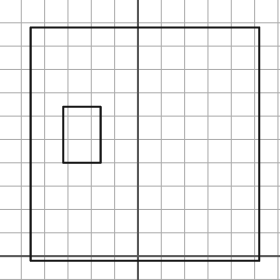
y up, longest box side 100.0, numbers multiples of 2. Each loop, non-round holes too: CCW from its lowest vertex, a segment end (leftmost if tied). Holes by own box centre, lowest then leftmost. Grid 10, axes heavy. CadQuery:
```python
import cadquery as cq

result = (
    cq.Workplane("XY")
    .moveTo(-46.0, -2.0)
    .lineTo(52.0, -2.0)
    .lineTo(52.0, 98.0)
    .lineTo(-46.0, 98.0)
    .close()
    .moveTo(-32.0, 40.0)
    .lineTo(-16.0, 40.0)
    .lineTo(-16.0, 64.0)
    .lineTo(-32.0, 64.0)
    .close()
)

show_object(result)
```